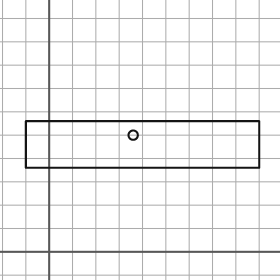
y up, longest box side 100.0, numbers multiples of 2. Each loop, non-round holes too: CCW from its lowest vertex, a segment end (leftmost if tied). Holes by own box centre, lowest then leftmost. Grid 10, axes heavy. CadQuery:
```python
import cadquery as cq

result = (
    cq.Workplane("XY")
    .moveTo(-10.0, 36.0)
    .lineTo(90.0, 36.0)
    .lineTo(90.0, 56.0)
    .lineTo(-10.0, 56.0)
    .close()
    .moveTo(36.0, 50.0)
    .circle(2.0)
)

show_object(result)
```